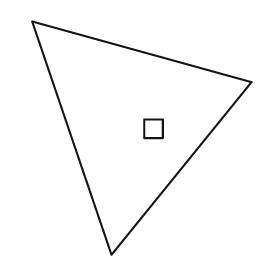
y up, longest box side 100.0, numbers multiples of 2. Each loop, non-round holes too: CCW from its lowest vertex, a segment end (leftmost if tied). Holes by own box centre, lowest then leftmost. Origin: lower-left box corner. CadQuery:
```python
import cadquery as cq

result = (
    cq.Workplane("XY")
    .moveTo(34.0, 0.0)
    .lineTo(94.0, 74.0)
    .lineTo(0.0, 100.0)
    .close()
    .moveTo(48.0, 50.0)
    .lineTo(56.0, 50.0)
    .lineTo(56.0, 58.0)
    .lineTo(48.0, 58.0)
    .close()
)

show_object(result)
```